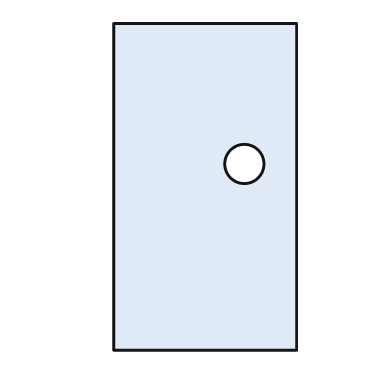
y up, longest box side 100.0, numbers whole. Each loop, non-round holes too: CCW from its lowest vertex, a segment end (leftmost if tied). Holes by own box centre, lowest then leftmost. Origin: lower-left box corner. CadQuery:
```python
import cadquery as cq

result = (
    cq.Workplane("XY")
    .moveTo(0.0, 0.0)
    .lineTo(56.0, 0.0)
    .lineTo(56.0, 100.0)
    .lineTo(0.0, 100.0)
    .close()
    .moveTo(40.0, 57.0)
    .circle(6.0)
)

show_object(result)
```